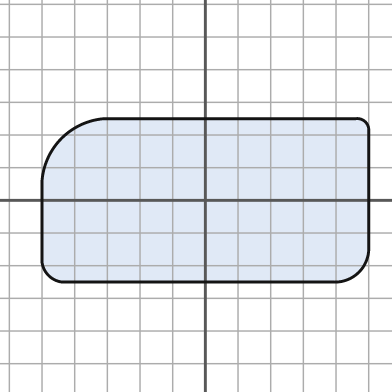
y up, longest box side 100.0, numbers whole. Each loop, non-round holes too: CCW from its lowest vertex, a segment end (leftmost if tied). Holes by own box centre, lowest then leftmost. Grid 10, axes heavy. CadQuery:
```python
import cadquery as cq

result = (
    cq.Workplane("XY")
    .moveTo(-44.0, -25.0)
    .lineTo(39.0, -25.0)
    .threePointArc((47.0, -22.0), (50.0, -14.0))
    .lineTo(50.0, 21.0)
    .threePointArc((49.0, 24.0), (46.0, 25.0))
    .lineTo(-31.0, 25.0)
    .threePointArc((-44.0, 19.0), (-50.0, 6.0))
    .lineTo(-50.0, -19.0)
    .threePointArc((-48.0, -23.0), (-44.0, -25.0))
    .close()
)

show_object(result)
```